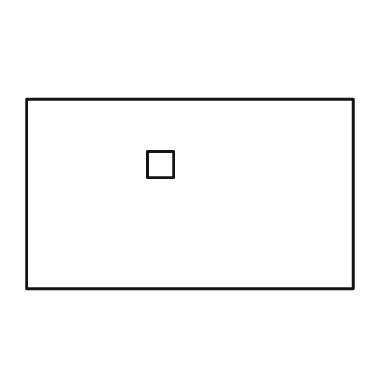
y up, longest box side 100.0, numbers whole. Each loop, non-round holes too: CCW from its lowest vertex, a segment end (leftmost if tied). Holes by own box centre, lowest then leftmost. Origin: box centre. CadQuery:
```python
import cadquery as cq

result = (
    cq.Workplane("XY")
    .moveTo(-50.0, -29.0)
    .lineTo(50.0, -29.0)
    .lineTo(50.0, 29.0)
    .lineTo(-50.0, 29.0)
    .close()
    .moveTo(-13.0, 5.0)
    .lineTo(-5.0, 5.0)
    .lineTo(-5.0, 13.0)
    .lineTo(-13.0, 13.0)
    .close()
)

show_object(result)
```